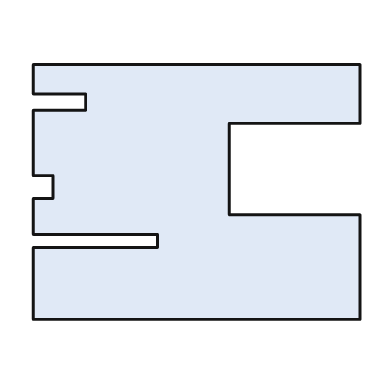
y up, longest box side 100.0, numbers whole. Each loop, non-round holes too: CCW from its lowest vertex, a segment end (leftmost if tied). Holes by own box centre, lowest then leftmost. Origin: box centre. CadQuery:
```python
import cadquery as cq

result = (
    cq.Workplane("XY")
    .moveTo(-50.0, -39.0)
    .lineTo(50.0, -39.0)
    .lineTo(50.0, -7.0)
    .lineTo(10.0, -7.0)
    .lineTo(10.0, 21.0)
    .lineTo(50.0, 21.0)
    .lineTo(50.0, 39.0)
    .lineTo(-50.0, 39.0)
    .lineTo(-50.0, 30.0)
    .lineTo(-34.0, 30.0)
    .lineTo(-34.0, 25.0)
    .lineTo(-50.0, 25.0)
    .lineTo(-50.0, 5.0)
    .lineTo(-44.0, 5.0)
    .lineTo(-44.0, -2.0)
    .lineTo(-50.0, -2.0)
    .lineTo(-50.0, -13.0)
    .lineTo(-12.0, -13.0)
    .lineTo(-12.0, -17.0)
    .lineTo(-50.0, -17.0)
    .close()
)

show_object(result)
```